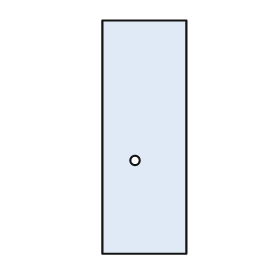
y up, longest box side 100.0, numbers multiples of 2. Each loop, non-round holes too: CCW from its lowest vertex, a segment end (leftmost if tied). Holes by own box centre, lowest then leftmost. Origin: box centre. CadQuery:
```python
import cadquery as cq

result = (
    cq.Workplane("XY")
    .moveTo(-18.0, -50.0)
    .lineTo(18.0, -50.0)
    .lineTo(18.0, 50.0)
    .lineTo(-18.0, 50.0)
    .close()
    .moveTo(-4.0, -10.0)
    .circle(2.0)
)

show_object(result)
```